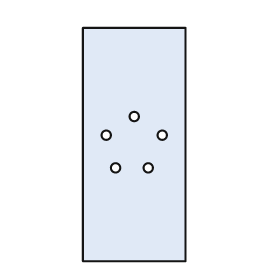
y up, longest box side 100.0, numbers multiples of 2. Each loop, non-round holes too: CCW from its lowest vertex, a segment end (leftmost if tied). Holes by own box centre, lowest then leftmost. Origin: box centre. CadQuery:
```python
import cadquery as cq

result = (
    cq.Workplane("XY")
    .moveTo(-22.0, -50.0)
    .lineTo(22.0, -50.0)
    .lineTo(22.0, 50.0)
    .lineTo(-22.0, 50.0)
    .close()
    .moveTo(-8.0, -10.0)
    .circle(2.0)
    .moveTo(6.0, -10.0)
    .circle(2.0)
    .moveTo(-12.0, 4.0)
    .circle(2.0)
    .moveTo(12.0, 4.0)
    .circle(2.0)
    .moveTo(0.0, 12.0)
    .circle(2.0)
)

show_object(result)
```